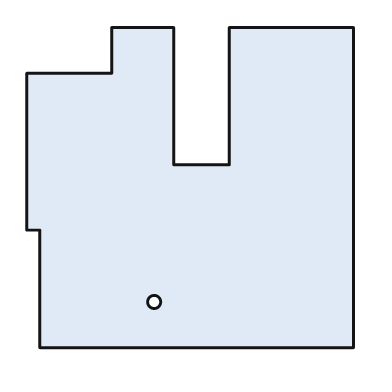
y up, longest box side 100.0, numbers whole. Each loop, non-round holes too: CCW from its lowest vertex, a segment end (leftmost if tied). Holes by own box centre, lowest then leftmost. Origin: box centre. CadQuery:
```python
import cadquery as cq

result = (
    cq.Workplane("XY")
    .moveTo(-46.0, -49.0)
    .lineTo(50.0, -49.0)
    .lineTo(50.0, 49.0)
    .lineTo(12.0, 49.0)
    .lineTo(12.0, 7.0)
    .lineTo(-5.0, 7.0)
    .lineTo(-5.0, 49.0)
    .lineTo(-24.0, 49.0)
    .lineTo(-24.0, 35.0)
    .lineTo(-50.0, 35.0)
    .lineTo(-50.0, -13.0)
    .lineTo(-46.0, -13.0)
    .close()
    .moveTo(-11.0, -35.0)
    .circle(2.0)
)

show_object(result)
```